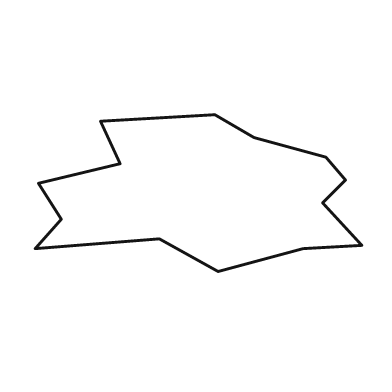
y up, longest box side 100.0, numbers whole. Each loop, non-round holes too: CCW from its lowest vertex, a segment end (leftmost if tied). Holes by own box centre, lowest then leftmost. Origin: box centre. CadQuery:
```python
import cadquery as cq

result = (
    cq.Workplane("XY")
    .moveTo(6.0, -24.0)
    .lineTo(32.0, -17.0)
    .lineTo(50.0, -16.0)
    .lineTo(38.0, -3.0)
    .lineTo(45.0, 4.0)
    .lineTo(39.0, 11.0)
    .lineTo(17.0, 17.0)
    .lineTo(5.0, 24.0)
    .lineTo(-30.0, 22.0)
    .lineTo(-24.0, 9.0)
    .lineTo(-49.0, 3.0)
    .lineTo(-42.0, -8.0)
    .lineTo(-50.0, -17.0)
    .lineTo(-12.0, -14.0)
    .close()
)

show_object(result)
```